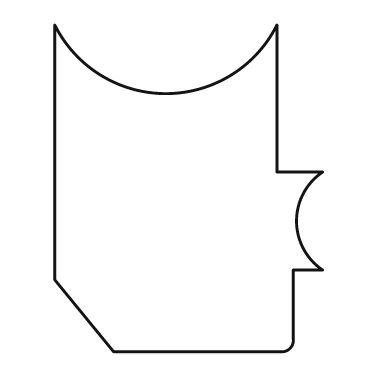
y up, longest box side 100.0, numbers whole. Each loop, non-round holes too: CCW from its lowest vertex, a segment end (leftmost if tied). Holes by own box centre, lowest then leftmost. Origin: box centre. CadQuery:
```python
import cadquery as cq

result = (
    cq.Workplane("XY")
    .moveTo(-23.0, -50.0)
    .lineTo(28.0, -50.0)
    .threePointArc((31.0, -49.0), (32.0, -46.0))
    .lineTo(32.0, -25.0)
    .lineTo(41.0, -25.0)
    .threePointArc((33.0, -10.0), (41.0, 5.0))
    .lineTo(27.0, 5.0)
    .lineTo(27.0, 50.0)
    .threePointArc((-7.0, 29.0), (-41.0, 50.0))
    .lineTo(-41.0, -28.0)
    .close()
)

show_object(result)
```